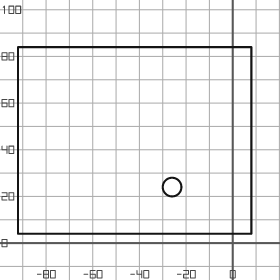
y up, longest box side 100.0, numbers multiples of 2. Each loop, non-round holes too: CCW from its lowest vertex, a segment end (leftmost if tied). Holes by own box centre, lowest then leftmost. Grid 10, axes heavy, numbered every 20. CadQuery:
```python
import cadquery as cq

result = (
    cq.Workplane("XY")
    .moveTo(-92.0, 4.0)
    .lineTo(8.0, 4.0)
    .lineTo(8.0, 84.0)
    .lineTo(-92.0, 84.0)
    .close()
    .moveTo(-26.0, 24.0)
    .circle(4.0)
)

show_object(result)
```